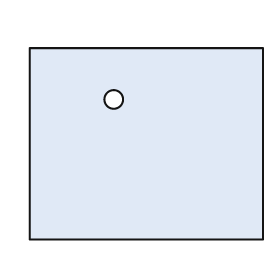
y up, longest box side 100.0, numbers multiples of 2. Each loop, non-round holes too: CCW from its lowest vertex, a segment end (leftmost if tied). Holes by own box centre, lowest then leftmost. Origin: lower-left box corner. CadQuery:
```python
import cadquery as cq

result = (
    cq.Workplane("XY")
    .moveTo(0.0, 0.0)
    .lineTo(100.0, 0.0)
    .lineTo(100.0, 82.0)
    .lineTo(0.0, 82.0)
    .close()
    .moveTo(36.0, 60.0)
    .circle(4.0)
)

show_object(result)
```